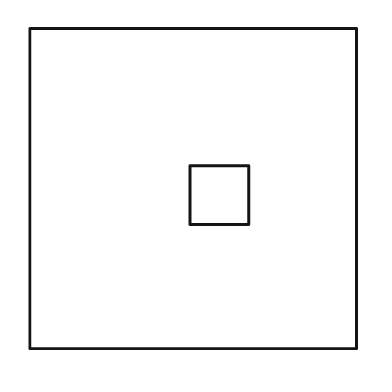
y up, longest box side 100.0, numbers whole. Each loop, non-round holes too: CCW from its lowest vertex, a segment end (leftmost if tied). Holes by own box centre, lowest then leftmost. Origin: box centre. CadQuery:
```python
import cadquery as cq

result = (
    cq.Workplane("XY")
    .moveTo(-50.0, -49.0)
    .lineTo(50.0, -49.0)
    .lineTo(50.0, 49.0)
    .lineTo(-50.0, 49.0)
    .close()
    .moveTo(-1.0, -11.0)
    .lineTo(17.0, -11.0)
    .lineTo(17.0, 7.0)
    .lineTo(-1.0, 7.0)
    .close()
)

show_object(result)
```